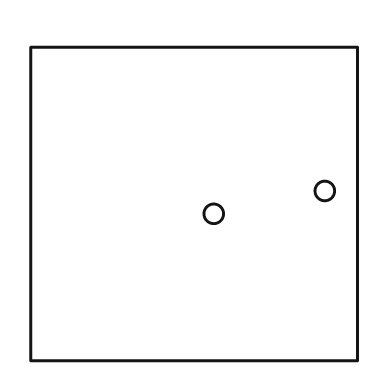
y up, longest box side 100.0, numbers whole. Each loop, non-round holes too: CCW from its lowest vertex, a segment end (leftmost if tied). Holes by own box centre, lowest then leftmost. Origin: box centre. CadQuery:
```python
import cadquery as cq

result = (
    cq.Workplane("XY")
    .moveTo(-50.0, -48.0)
    .lineTo(50.0, -48.0)
    .lineTo(50.0, 48.0)
    .lineTo(-50.0, 48.0)
    .close()
    .moveTo(6.0, -3.0)
    .circle(3.0)
    .moveTo(40.0, 4.0)
    .circle(3.0)
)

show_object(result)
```